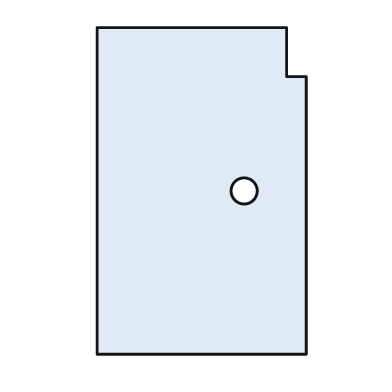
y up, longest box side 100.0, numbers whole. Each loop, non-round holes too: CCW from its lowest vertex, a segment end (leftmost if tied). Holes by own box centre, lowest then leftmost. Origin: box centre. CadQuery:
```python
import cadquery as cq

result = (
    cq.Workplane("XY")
    .moveTo(-32.0, -50.0)
    .lineTo(32.0, -50.0)
    .lineTo(32.0, 35.0)
    .lineTo(26.0, 35.0)
    .lineTo(26.0, 50.0)
    .lineTo(-32.0, 50.0)
    .close()
    .moveTo(13.0, 0.0)
    .circle(4.0)
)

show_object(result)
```